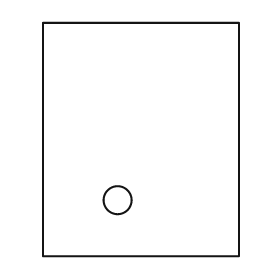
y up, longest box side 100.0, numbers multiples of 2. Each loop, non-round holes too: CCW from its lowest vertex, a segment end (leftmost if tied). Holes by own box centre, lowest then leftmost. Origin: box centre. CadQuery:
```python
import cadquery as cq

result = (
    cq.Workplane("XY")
    .moveTo(-42.0, -50.0)
    .lineTo(42.0, -50.0)
    .lineTo(42.0, 50.0)
    .lineTo(-42.0, 50.0)
    .close()
    .moveTo(-10.0, -26.0)
    .circle(6.0)
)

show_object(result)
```